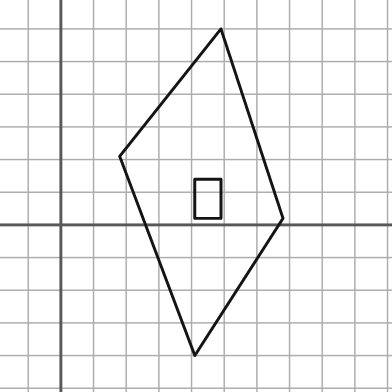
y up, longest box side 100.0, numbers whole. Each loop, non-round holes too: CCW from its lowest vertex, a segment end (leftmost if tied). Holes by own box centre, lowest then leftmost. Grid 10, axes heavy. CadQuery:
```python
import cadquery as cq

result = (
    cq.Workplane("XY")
    .moveTo(41.0, -40.0)
    .lineTo(68.0, 2.0)
    .lineTo(49.0, 60.0)
    .lineTo(18.0, 21.0)
    .close()
    .moveTo(41.0, 2.0)
    .lineTo(49.0, 2.0)
    .lineTo(49.0, 14.0)
    .lineTo(41.0, 14.0)
    .close()
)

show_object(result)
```